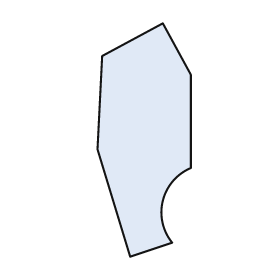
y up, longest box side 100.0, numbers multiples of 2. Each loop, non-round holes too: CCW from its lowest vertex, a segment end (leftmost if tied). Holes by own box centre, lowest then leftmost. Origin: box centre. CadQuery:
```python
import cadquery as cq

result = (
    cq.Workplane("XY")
    .moveTo(-6.0, -50.0)
    .lineTo(12.0, -44.0)
    .threePointArc((8.0, -26.0), (20.0, -12.0))
    .lineTo(20.0, 28.0)
    .lineTo(8.0, 50.0)
    .lineTo(-18.0, 36.0)
    .lineTo(-20.0, -4.0)
    .close()
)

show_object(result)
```